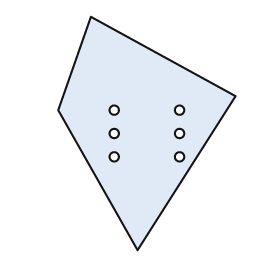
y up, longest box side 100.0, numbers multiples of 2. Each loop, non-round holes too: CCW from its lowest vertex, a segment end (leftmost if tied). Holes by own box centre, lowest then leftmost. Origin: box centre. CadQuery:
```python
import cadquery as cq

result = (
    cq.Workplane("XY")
    .moveTo(-4.0, -50.0)
    .lineTo(38.0, 16.0)
    .lineTo(-24.0, 50.0)
    .lineTo(-38.0, 10.0)
    .close()
    .moveTo(-14.0, -10.0)
    .circle(2.0)
    .moveTo(14.0, -10.0)
    .circle(2.0)
    .moveTo(-14.0, 0.0)
    .circle(2.0)
    .moveTo(14.0, 0.0)
    .circle(2.0)
    .moveTo(-14.0, 10.0)
    .circle(2.0)
    .moveTo(14.0, 10.0)
    .circle(2.0)
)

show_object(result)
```